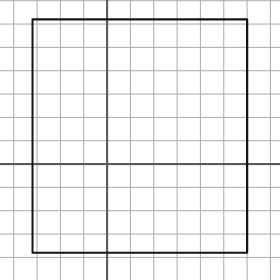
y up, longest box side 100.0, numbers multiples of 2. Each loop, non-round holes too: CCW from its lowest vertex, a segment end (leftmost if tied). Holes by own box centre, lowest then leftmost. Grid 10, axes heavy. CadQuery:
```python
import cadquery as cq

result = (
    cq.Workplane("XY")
    .moveTo(-32.0, -38.0)
    .lineTo(60.0, -38.0)
    .lineTo(60.0, 62.0)
    .lineTo(-32.0, 62.0)
    .close()
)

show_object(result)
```